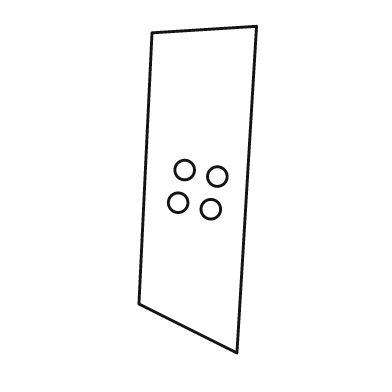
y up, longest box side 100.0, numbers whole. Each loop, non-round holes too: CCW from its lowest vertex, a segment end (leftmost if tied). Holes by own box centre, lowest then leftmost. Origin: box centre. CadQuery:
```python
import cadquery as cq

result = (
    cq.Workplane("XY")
    .moveTo(12.0, -50.0)
    .lineTo(18.0, 50.0)
    .lineTo(-14.0, 48.0)
    .lineTo(-18.0, -35.0)
    .close()
    .moveTo(4.0, -6.0)
    .circle(3.0)
    .moveTo(-6.0, -4.0)
    .circle(3.0)
    .moveTo(6.0, 4.0)
    .circle(3.0)
    .moveTo(-4.0, 6.0)
    .circle(3.0)
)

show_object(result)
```